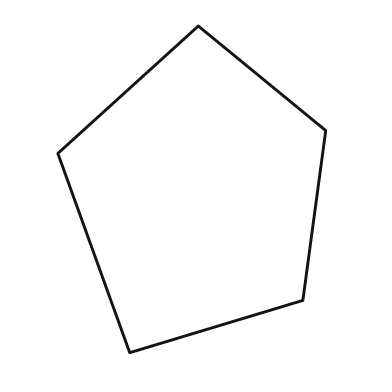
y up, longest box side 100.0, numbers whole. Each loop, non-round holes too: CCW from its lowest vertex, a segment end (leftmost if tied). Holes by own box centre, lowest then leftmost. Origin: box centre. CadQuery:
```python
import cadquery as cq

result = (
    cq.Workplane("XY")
    .moveTo(-19.0, -50.0)
    .lineTo(34.0, -34.0)
    .lineTo(41.0, 18.0)
    .lineTo(2.0, 50.0)
    .lineTo(-41.0, 11.0)
    .close()
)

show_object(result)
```